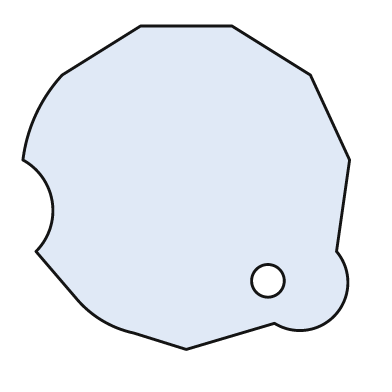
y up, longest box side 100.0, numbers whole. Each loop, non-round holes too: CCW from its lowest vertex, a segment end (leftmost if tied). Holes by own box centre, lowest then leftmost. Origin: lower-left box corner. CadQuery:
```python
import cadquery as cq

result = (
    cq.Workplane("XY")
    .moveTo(50.0, 0.0)
    .lineTo(77.0, 8.0)
    .threePointArc((96.0, 11.0), (96.0, 30.0))
    .lineTo(100.0, 58.0)
    .lineTo(88.0, 84.0)
    .lineTo(64.0, 99.0)
    .lineTo(36.0, 99.0)
    .lineTo(12.0, 84.0)
    .threePointArc((4.0, 72.0), (0.0, 58.0))
    .threePointArc((9.0, 45.0), (4.0, 30.0))
    .lineTo(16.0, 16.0)
    .threePointArc((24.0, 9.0), (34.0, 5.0))
    .close()
    .moveTo(75.0, 21.0)
    .circle(5.0)
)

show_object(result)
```